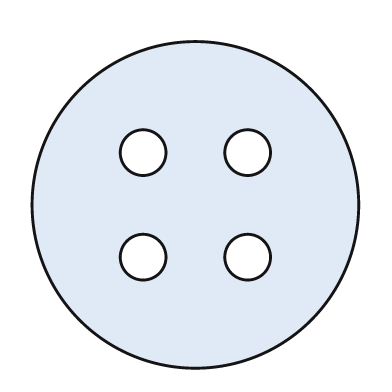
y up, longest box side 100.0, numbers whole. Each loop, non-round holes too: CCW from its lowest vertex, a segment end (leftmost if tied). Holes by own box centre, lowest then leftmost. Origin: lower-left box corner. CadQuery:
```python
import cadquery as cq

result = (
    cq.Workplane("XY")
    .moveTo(50.0, 50.0)
    .circle(50.0)
    .moveTo(34.0, 34.0)
    .circle(7.0)
    .moveTo(66.0, 34.0)
    .circle(7.0)
    .moveTo(34.0, 66.0)
    .circle(7.0)
    .moveTo(66.0, 66.0)
    .circle(7.0)
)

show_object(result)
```